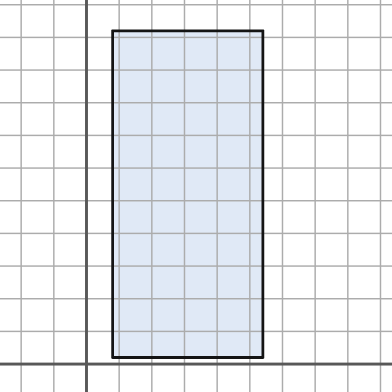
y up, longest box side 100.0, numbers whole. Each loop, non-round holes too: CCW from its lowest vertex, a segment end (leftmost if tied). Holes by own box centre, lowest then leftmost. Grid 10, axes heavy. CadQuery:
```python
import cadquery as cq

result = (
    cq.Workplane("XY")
    .moveTo(8.0, 2.0)
    .lineTo(54.0, 2.0)
    .lineTo(54.0, 102.0)
    .lineTo(8.0, 102.0)
    .close()
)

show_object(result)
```